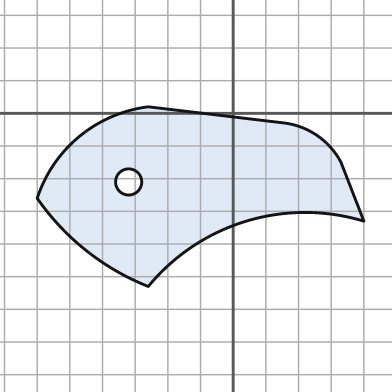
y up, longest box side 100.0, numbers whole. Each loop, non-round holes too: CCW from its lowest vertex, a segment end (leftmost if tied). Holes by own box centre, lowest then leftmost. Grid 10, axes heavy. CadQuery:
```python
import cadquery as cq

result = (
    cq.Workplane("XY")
    .moveTo(-26.0, -53.0)
    .threePointArc((4.0, -33.0), (40.0, -33.0))
    .lineTo(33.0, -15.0)
    .threePointArc((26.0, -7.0), (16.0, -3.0))
    .lineTo(-26.0, 2.0)
    .threePointArc((-47.0, -7.0), (-60.0, -26.0))
    .threePointArc((-45.0, -42.0), (-26.0, -53.0))
    .close()
    .moveTo(-32.0, -21.0)
    .circle(4.0)
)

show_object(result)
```